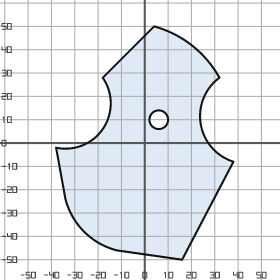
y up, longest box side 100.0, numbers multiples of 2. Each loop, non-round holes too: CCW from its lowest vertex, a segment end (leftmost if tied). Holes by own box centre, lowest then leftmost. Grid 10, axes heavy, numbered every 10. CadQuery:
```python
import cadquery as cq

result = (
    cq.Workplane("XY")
    .moveTo(16.0, -50.0)
    .lineTo(38.0, -8.0)
    .threePointArc((24.0, 8.0), (32.0, 28.0))
    .threePointArc((20.0, 42.0), (4.0, 50.0))
    .lineTo(-18.0, 28.0)
    .threePointArc((-18.0, 6.0), (-38.0, -2.0))
    .lineTo(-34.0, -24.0)
    .threePointArc((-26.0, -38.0), (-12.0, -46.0))
    .close()
    .moveTo(6.0, 10.0)
    .circle(4.0)
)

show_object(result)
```